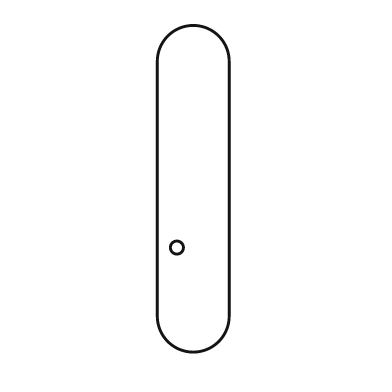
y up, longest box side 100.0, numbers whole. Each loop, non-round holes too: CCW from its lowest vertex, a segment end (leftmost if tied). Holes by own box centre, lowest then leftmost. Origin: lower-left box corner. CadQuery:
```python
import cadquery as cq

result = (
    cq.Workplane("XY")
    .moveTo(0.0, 11.0)
    .threePointArc((11.0, 0.0), (22.0, 11.0))
    .lineTo(22.0, 89.0)
    .threePointArc((11.0, 100.0), (0.0, 89.0))
    .close()
    .moveTo(6.0, 32.0)
    .circle(2.0)
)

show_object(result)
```